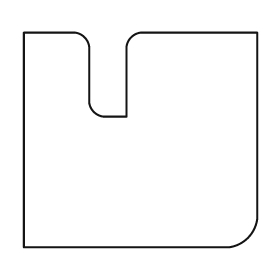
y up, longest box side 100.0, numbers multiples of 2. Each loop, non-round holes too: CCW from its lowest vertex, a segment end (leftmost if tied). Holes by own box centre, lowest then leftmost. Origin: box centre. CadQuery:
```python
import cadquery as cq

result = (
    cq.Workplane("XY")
    .moveTo(-50.0, -46.0)
    .lineTo(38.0, -46.0)
    .threePointArc((46.0, -42.0), (50.0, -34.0))
    .lineTo(50.0, 46.0)
    .lineTo(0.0, 46.0)
    .threePointArc((-4.0, 44.0), (-6.0, 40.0))
    .lineTo(-6.0, 10.0)
    .lineTo(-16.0, 10.0)
    .threePointArc((-20.0, 12.0), (-22.0, 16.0))
    .lineTo(-22.0, 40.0)
    .threePointArc((-24.0, 44.0), (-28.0, 46.0))
    .lineTo(-50.0, 46.0)
    .close()
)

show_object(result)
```